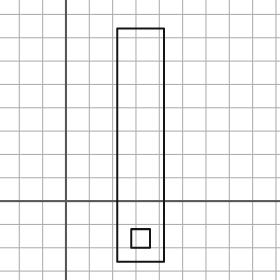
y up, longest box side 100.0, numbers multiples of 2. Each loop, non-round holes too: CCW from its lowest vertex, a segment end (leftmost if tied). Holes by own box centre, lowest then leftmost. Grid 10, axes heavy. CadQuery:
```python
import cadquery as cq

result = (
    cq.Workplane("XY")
    .moveTo(22.0, -26.0)
    .lineTo(42.0, -26.0)
    .lineTo(42.0, 74.0)
    .lineTo(22.0, 74.0)
    .close()
    .moveTo(28.0, -20.0)
    .lineTo(36.0, -20.0)
    .lineTo(36.0, -12.0)
    .lineTo(28.0, -12.0)
    .close()
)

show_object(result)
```